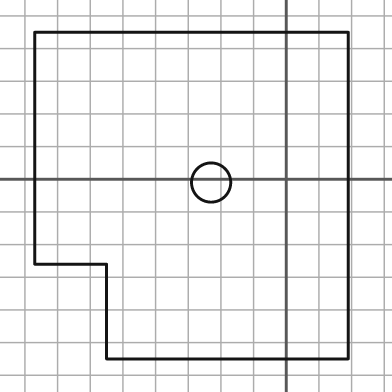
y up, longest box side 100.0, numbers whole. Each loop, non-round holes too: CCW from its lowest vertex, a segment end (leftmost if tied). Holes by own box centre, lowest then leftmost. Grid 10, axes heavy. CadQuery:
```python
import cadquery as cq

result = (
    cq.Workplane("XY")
    .moveTo(-55.0, -55.0)
    .lineTo(19.0, -55.0)
    .lineTo(19.0, 45.0)
    .lineTo(-77.0, 45.0)
    .lineTo(-77.0, -26.0)
    .lineTo(-55.0, -26.0)
    .close()
    .moveTo(-23.0, -1.0)
    .circle(6.0)
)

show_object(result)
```